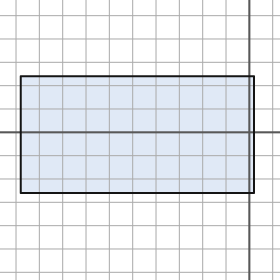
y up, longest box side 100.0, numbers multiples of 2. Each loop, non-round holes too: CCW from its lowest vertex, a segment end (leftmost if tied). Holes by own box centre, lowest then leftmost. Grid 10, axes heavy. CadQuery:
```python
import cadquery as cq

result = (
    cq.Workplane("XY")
    .moveTo(-98.0, -26.0)
    .lineTo(2.0, -26.0)
    .lineTo(2.0, 24.0)
    .lineTo(-98.0, 24.0)
    .close()
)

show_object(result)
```